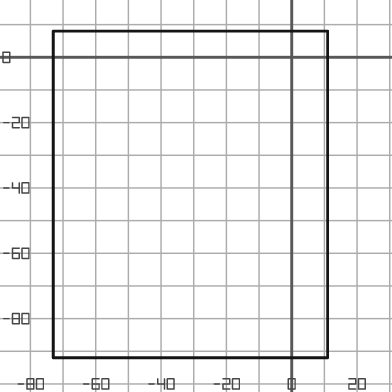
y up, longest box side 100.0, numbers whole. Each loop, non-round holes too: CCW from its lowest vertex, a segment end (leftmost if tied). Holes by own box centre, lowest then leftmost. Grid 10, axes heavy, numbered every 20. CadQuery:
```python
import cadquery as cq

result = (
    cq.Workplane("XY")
    .moveTo(-73.0, -92.0)
    .lineTo(11.0, -92.0)
    .lineTo(11.0, 8.0)
    .lineTo(-73.0, 8.0)
    .close()
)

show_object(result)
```